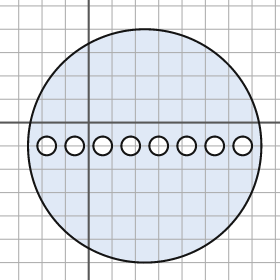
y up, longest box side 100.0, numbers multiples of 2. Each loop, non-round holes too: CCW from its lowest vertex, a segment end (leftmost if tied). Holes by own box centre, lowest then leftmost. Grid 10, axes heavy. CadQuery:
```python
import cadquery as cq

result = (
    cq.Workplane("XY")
    .moveTo(24.0, -10.0)
    .circle(50.0)
    .moveTo(-18.0, -10.0)
    .circle(4.0)
    .moveTo(-6.0, -10.0)
    .circle(4.0)
    .moveTo(6.0, -10.0)
    .circle(4.0)
    .moveTo(18.0, -10.0)
    .circle(4.0)
    .moveTo(30.0, -10.0)
    .circle(4.0)
    .moveTo(42.0, -10.0)
    .circle(4.0)
    .moveTo(54.0, -10.0)
    .circle(4.0)
    .moveTo(66.0, -10.0)
    .circle(4.0)
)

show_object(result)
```